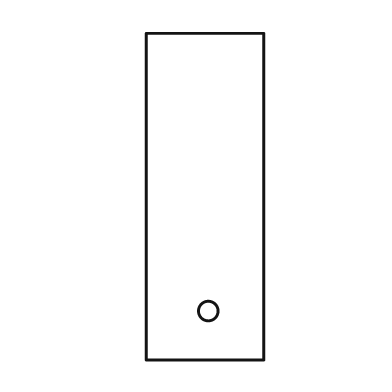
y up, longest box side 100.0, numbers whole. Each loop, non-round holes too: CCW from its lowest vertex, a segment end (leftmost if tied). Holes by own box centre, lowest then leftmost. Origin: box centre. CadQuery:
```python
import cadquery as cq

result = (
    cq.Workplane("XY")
    .moveTo(-18.0, -50.0)
    .lineTo(18.0, -50.0)
    .lineTo(18.0, 50.0)
    .lineTo(-18.0, 50.0)
    .close()
    .moveTo(1.0, -35.0)
    .circle(3.0)
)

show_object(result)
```